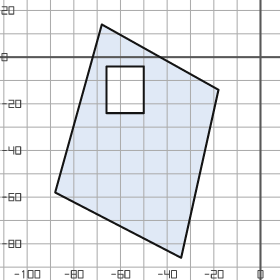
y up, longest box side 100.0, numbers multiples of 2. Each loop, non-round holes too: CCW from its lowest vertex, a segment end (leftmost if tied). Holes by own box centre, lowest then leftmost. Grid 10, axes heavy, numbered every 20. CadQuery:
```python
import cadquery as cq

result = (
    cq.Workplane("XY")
    .moveTo(-34.0, -86.0)
    .lineTo(-18.0, -14.0)
    .lineTo(-68.0, 14.0)
    .lineTo(-88.0, -58.0)
    .close()
    .moveTo(-66.0, -24.0)
    .lineTo(-50.0, -24.0)
    .lineTo(-50.0, -4.0)
    .lineTo(-66.0, -4.0)
    .close()
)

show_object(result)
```